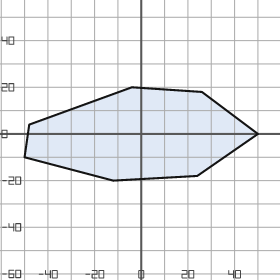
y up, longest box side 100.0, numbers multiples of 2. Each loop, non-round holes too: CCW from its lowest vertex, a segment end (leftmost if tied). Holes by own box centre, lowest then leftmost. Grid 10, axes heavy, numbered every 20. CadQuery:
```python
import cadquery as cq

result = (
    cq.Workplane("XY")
    .moveTo(-12.0, -20.0)
    .lineTo(24.0, -18.0)
    .lineTo(50.0, 0.0)
    .lineTo(26.0, 18.0)
    .lineTo(-4.0, 20.0)
    .lineTo(-48.0, 4.0)
    .lineTo(-50.0, -10.0)
    .close()
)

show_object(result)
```